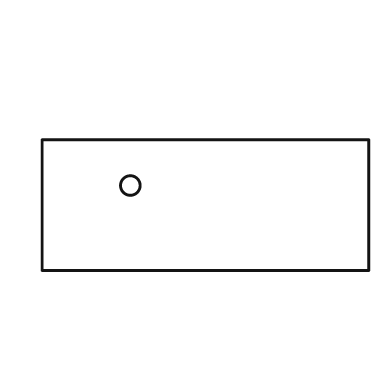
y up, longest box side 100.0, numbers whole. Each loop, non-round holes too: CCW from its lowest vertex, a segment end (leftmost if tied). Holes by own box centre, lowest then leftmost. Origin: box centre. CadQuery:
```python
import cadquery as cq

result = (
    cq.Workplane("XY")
    .moveTo(-50.0, -20.0)
    .lineTo(50.0, -20.0)
    .lineTo(50.0, 20.0)
    .lineTo(-50.0, 20.0)
    .close()
    .moveTo(-23.0, 6.0)
    .circle(3.0)
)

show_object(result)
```